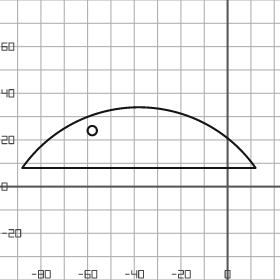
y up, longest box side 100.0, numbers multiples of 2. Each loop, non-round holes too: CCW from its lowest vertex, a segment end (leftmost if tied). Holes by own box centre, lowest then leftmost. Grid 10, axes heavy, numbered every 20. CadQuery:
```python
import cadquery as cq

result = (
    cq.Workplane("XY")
    .moveTo(-88.0, 8.0)
    .lineTo(12.0, 8.0)
    .threePointArc((-38.0, 34.0), (-88.0, 8.0))
    .close()
    .moveTo(-58.0, 24.0)
    .circle(2.0)
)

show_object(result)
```